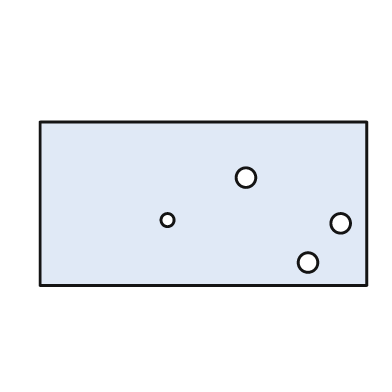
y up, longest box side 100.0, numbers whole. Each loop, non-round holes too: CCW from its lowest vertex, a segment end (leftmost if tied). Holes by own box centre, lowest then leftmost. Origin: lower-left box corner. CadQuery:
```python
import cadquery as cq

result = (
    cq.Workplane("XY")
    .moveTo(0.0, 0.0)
    .lineTo(100.0, 0.0)
    .lineTo(100.0, 50.0)
    .lineTo(0.0, 50.0)
    .close()
    .moveTo(82.0, 7.0)
    .circle(3.0)
    .moveTo(92.0, 19.0)
    .circle(3.0)
    .moveTo(39.0, 20.0)
    .circle(2.0)
    .moveTo(63.0, 33.0)
    .circle(3.0)
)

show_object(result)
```